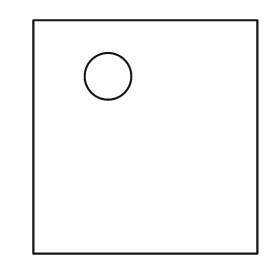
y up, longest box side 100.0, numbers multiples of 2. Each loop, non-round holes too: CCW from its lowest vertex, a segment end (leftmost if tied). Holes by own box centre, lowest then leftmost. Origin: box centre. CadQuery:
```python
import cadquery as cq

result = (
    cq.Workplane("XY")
    .moveTo(-48.0, -50.0)
    .lineTo(48.0, -50.0)
    .lineTo(48.0, 50.0)
    .lineTo(-48.0, 50.0)
    .close()
    .moveTo(-16.0, 26.0)
    .circle(10.0)
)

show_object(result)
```